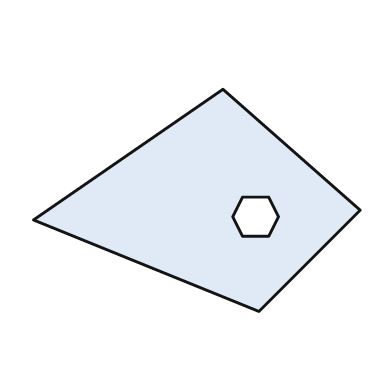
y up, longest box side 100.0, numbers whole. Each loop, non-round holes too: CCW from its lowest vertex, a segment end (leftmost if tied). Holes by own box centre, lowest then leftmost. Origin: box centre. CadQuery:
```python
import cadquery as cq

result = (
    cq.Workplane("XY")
    .moveTo(19.0, -34.0)
    .lineTo(50.0, -3.0)
    .lineTo(8.0, 34.0)
    .lineTo(-50.0, -6.0)
    .close()
    .moveTo(14.0, -11.0)
    .lineTo(22.0, -11.0)
    .lineTo(25.0, -5.0)
    .lineTo(22.0, 1.0)
    .lineTo(14.0, 1.0)
    .lineTo(11.0, -5.0)
    .close()
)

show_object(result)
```